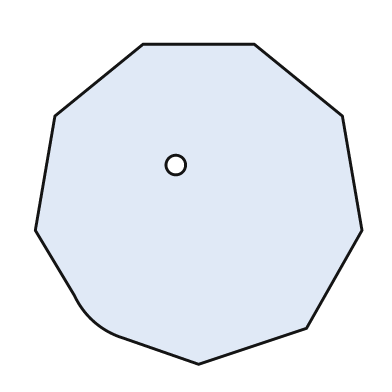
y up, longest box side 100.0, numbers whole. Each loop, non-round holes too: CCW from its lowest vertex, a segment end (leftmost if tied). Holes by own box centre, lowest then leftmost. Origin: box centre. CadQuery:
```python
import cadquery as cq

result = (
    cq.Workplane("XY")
    .moveTo(0.0, -49.0)
    .lineTo(33.0, -38.0)
    .lineTo(50.0, -8.0)
    .lineTo(44.0, 27.0)
    .lineTo(17.0, 49.0)
    .lineTo(-17.0, 49.0)
    .lineTo(-44.0, 27.0)
    .lineTo(-50.0, -8.0)
    .lineTo(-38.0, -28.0)
    .threePointArc((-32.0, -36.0), (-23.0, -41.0))
    .close()
    .moveTo(-7.0, 12.0)
    .circle(3.0)
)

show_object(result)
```